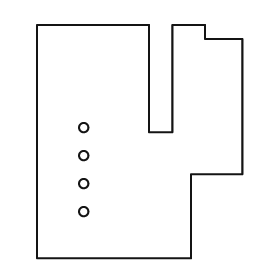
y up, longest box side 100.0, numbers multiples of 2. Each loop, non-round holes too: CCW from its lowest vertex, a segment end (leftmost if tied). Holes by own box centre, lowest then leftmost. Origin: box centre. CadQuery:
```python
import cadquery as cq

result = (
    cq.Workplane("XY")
    .moveTo(-44.0, -50.0)
    .lineTo(22.0, -50.0)
    .lineTo(22.0, -14.0)
    .lineTo(44.0, -14.0)
    .lineTo(44.0, 44.0)
    .lineTo(28.0, 44.0)
    .lineTo(28.0, 50.0)
    .lineTo(14.0, 50.0)
    .lineTo(14.0, 4.0)
    .lineTo(4.0, 4.0)
    .lineTo(4.0, 50.0)
    .lineTo(-44.0, 50.0)
    .close()
    .moveTo(-24.0, -30.0)
    .circle(2.0)
    .moveTo(-24.0, -18.0)
    .circle(2.0)
    .moveTo(-24.0, -6.0)
    .circle(2.0)
    .moveTo(-24.0, 6.0)
    .circle(2.0)
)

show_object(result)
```